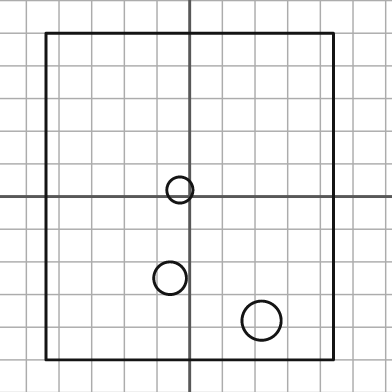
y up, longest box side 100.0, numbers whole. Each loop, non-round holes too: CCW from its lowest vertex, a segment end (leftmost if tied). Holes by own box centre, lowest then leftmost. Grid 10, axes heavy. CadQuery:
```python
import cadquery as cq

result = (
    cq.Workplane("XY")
    .moveTo(-44.0, -50.0)
    .lineTo(44.0, -50.0)
    .lineTo(44.0, 50.0)
    .lineTo(-44.0, 50.0)
    .close()
    .moveTo(22.0, -38.0)
    .circle(6.0)
    .moveTo(-6.0, -25.0)
    .circle(5.0)
    .moveTo(-3.0, 2.0)
    .circle(4.0)
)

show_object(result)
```